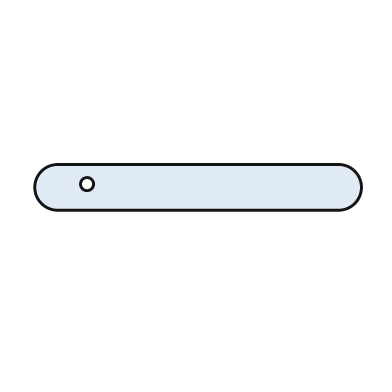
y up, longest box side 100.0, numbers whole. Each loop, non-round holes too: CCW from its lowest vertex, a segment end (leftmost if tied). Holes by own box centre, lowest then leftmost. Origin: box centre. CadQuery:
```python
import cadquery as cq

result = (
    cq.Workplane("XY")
    .moveTo(-43.0, -7.0)
    .lineTo(43.0, -7.0)
    .threePointArc((50.0, 0.0), (43.0, 7.0))
    .lineTo(-43.0, 7.0)
    .threePointArc((-50.0, 0.0), (-43.0, -7.0))
    .close()
    .moveTo(-34.0, 1.0)
    .circle(2.0)
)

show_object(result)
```